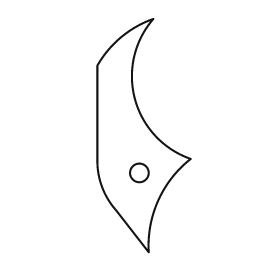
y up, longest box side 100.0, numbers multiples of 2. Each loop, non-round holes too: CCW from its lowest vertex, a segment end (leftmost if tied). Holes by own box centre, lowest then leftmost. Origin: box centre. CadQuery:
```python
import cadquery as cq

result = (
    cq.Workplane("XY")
    .moveTo(2.0, -50.0)
    .threePointArc((6.0, -28.0), (20.0, -10.0))
    .threePointArc((-4.0, 16.0), (4.0, 50.0))
    .threePointArc((-10.0, 42.0), (-20.0, 30.0))
    .lineTo(-20.0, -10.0)
    .threePointArc((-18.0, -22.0), (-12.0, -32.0))
    .close()
    .moveTo(-2.0, -16.0)
    .circle(4.0)
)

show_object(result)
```